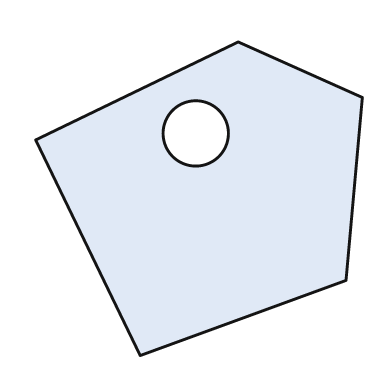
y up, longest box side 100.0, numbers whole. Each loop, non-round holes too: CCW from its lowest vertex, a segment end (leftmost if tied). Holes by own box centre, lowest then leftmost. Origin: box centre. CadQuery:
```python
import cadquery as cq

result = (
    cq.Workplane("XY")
    .moveTo(-18.0, -48.0)
    .lineTo(45.0, -25.0)
    .lineTo(50.0, 31.0)
    .lineTo(12.0, 48.0)
    .lineTo(-50.0, 18.0)
    .close()
    .moveTo(-1.0, 20.0)
    .circle(10.0)
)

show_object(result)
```